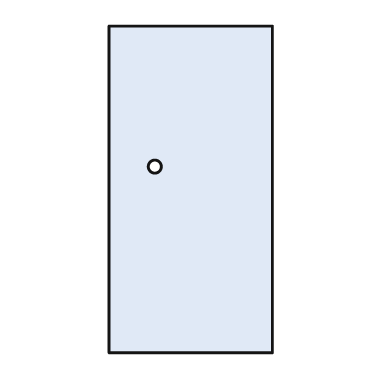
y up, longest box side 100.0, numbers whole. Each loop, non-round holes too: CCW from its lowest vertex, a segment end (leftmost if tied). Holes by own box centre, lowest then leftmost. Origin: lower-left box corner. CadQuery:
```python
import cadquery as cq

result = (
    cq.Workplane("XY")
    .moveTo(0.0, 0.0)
    .lineTo(50.0, 0.0)
    .lineTo(50.0, 100.0)
    .lineTo(0.0, 100.0)
    .close()
    .moveTo(14.0, 57.0)
    .circle(2.0)
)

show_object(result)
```